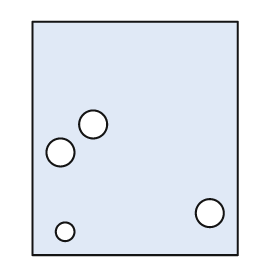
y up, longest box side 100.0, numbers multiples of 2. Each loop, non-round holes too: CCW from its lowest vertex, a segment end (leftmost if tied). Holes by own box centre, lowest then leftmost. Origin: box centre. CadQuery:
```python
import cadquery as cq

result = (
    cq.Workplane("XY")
    .moveTo(-44.0, -50.0)
    .lineTo(44.0, -50.0)
    .lineTo(44.0, 50.0)
    .lineTo(-44.0, 50.0)
    .close()
    .moveTo(-30.0, -40.0)
    .circle(4.0)
    .moveTo(32.0, -32.0)
    .circle(6.0)
    .moveTo(-32.0, -6.0)
    .circle(6.0)
    .moveTo(-18.0, 6.0)
    .circle(6.0)
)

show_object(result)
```